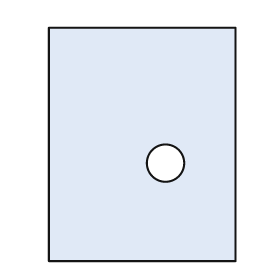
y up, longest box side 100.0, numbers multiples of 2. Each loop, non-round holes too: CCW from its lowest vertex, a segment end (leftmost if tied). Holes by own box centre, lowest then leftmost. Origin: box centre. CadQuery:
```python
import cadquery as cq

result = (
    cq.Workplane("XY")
    .moveTo(-40.0, -50.0)
    .lineTo(40.0, -50.0)
    .lineTo(40.0, 50.0)
    .lineTo(-40.0, 50.0)
    .close()
    .moveTo(10.0, -8.0)
    .circle(8.0)
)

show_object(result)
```